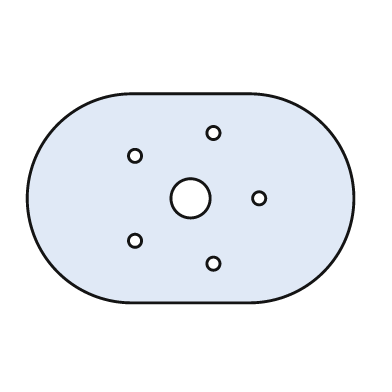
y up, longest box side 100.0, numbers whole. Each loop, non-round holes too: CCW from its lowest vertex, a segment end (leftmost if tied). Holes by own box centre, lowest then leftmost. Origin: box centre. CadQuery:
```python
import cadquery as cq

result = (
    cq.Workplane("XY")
    .moveTo(-18.0, -32.0)
    .lineTo(18.0, -32.0)
    .threePointArc((50.0, 0.0), (18.0, 32.0))
    .lineTo(-18.0, 32.0)
    .threePointArc((-50.0, 0.0), (-18.0, -32.0))
    .close()
    .moveTo(7.0, -20.0)
    .circle(2.0)
    .moveTo(-17.0, -13.0)
    .circle(2.0)
    .moveTo(0.0, 0.0)
    .circle(6.0)
    .moveTo(21.0, 0.0)
    .circle(2.0)
    .moveTo(-17.0, 13.0)
    .circle(2.0)
    .moveTo(7.0, 20.0)
    .circle(2.0)
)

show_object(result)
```